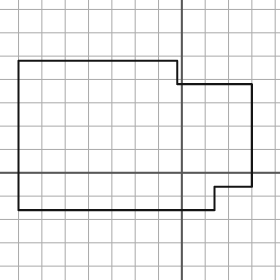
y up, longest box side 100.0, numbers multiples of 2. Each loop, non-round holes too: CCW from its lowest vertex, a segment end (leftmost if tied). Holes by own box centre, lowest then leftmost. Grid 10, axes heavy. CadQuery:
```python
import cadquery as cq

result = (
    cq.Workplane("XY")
    .moveTo(-70.0, -16.0)
    .lineTo(14.0, -16.0)
    .lineTo(14.0, -6.0)
    .lineTo(30.0, -6.0)
    .lineTo(30.0, 38.0)
    .lineTo(-2.0, 38.0)
    .lineTo(-2.0, 48.0)
    .lineTo(-70.0, 48.0)
    .close()
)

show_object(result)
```